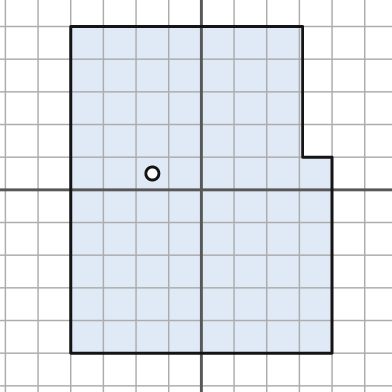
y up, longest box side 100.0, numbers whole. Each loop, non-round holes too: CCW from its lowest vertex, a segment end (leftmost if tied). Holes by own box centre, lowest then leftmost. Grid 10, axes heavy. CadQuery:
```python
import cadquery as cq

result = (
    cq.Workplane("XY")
    .moveTo(-40.0, -50.0)
    .lineTo(40.0, -50.0)
    .lineTo(40.0, 10.0)
    .lineTo(31.0, 10.0)
    .lineTo(31.0, 50.0)
    .lineTo(-40.0, 50.0)
    .close()
    .moveTo(-15.0, 5.0)
    .circle(2.0)
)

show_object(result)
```